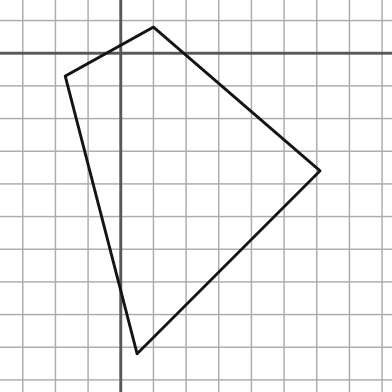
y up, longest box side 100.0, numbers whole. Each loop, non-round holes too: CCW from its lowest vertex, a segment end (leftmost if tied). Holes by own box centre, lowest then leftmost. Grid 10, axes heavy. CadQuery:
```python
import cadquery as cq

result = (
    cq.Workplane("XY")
    .moveTo(5.0, -92.0)
    .lineTo(61.0, -36.0)
    .lineTo(10.0, 8.0)
    .lineTo(-17.0, -7.0)
    .close()
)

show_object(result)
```